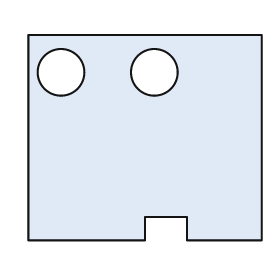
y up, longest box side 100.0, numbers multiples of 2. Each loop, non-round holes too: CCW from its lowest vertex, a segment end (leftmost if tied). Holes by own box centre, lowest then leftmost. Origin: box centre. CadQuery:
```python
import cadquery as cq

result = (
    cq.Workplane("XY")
    .moveTo(-50.0, -44.0)
    .lineTo(0.0, -44.0)
    .lineTo(0.0, -34.0)
    .lineTo(18.0, -34.0)
    .lineTo(18.0, -44.0)
    .lineTo(50.0, -44.0)
    .lineTo(50.0, 44.0)
    .lineTo(-50.0, 44.0)
    .close()
    .moveTo(-36.0, 28.0)
    .circle(10.0)
    .moveTo(4.0, 28.0)
    .circle(10.0)
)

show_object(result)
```